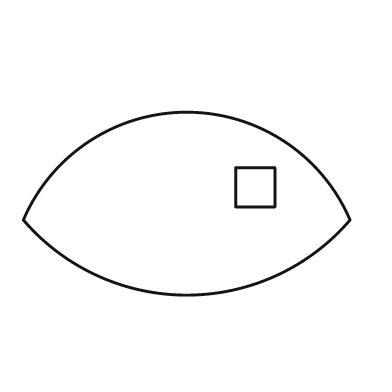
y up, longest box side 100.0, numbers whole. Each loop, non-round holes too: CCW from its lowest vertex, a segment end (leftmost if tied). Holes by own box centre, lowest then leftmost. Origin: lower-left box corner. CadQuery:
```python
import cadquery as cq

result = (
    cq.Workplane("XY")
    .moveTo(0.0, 23.0)
    .threePointArc((50.0, 0.0), (100.0, 23.0))
    .threePointArc((50.0, 56.0), (0.0, 23.0))
    .close()
    .moveTo(65.0, 27.0)
    .lineTo(77.0, 27.0)
    .lineTo(77.0, 39.0)
    .lineTo(65.0, 39.0)
    .close()
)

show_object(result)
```